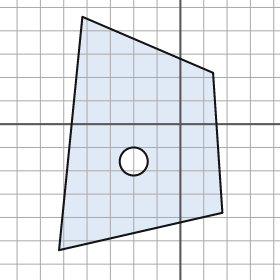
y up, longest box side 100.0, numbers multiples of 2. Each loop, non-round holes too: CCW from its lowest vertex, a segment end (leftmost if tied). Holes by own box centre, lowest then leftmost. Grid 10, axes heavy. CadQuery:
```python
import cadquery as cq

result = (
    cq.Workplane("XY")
    .moveTo(-52.0, -54.0)
    .lineTo(18.0, -38.0)
    .lineTo(14.0, 22.0)
    .lineTo(-42.0, 46.0)
    .close()
    .moveTo(-20.0, -16.0)
    .circle(6.0)
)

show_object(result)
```